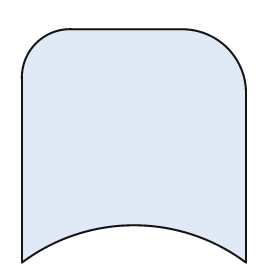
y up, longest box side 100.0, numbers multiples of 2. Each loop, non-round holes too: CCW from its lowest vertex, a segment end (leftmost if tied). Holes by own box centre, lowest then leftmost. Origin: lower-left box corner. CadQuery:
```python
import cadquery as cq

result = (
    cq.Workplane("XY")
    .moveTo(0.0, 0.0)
    .threePointArc((48.0, 16.0), (96.0, 0.0))
    .lineTo(96.0, 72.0)
    .threePointArc((88.0, 92.0), (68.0, 100.0))
    .lineTo(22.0, 100.0)
    .threePointArc((6.0, 94.0), (0.0, 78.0))
    .close()
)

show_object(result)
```